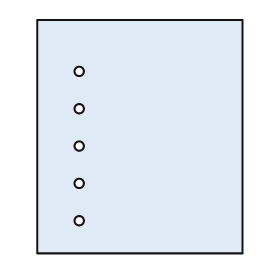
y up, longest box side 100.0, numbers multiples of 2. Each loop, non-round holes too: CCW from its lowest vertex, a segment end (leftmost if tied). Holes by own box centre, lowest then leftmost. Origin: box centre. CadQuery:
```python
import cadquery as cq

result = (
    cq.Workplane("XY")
    .moveTo(-44.0, -50.0)
    .lineTo(44.0, -50.0)
    .lineTo(44.0, 50.0)
    .lineTo(-44.0, 50.0)
    .close()
    .moveTo(-26.0, -36.0)
    .circle(2.0)
    .moveTo(-26.0, -20.0)
    .circle(2.0)
    .moveTo(-26.0, -4.0)
    .circle(2.0)
    .moveTo(-26.0, 12.0)
    .circle(2.0)
    .moveTo(-26.0, 28.0)
    .circle(2.0)
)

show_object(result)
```